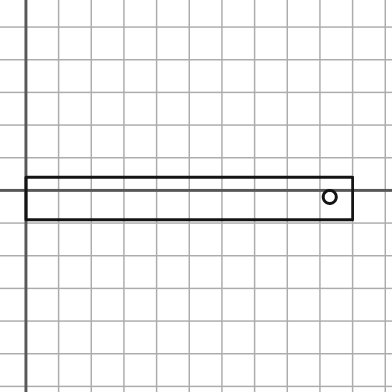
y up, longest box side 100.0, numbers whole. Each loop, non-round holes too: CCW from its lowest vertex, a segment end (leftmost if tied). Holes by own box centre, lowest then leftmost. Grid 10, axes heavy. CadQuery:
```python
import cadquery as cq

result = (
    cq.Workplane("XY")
    .moveTo(0.0, -9.0)
    .lineTo(100.0, -9.0)
    .lineTo(100.0, 4.0)
    .lineTo(0.0, 4.0)
    .close()
    .moveTo(93.0, -2.0)
    .circle(2.0)
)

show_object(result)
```